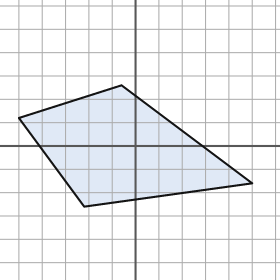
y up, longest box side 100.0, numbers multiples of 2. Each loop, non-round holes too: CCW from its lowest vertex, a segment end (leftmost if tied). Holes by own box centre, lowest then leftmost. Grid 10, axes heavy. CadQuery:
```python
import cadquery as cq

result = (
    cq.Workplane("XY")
    .moveTo(-22.0, -26.0)
    .lineTo(50.0, -16.0)
    .lineTo(-6.0, 26.0)
    .lineTo(-50.0, 12.0)
    .close()
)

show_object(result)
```